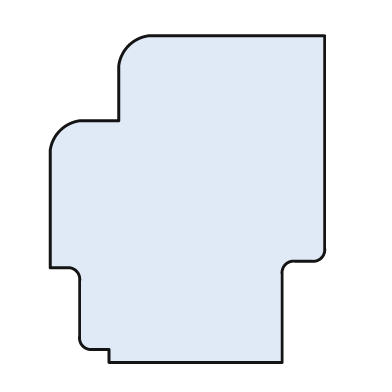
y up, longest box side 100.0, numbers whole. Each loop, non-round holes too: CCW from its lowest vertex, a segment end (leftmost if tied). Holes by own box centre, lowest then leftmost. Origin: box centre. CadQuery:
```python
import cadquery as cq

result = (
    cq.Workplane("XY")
    .moveTo(-24.0, -50.0)
    .lineTo(29.0, -50.0)
    .lineTo(29.0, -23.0)
    .threePointArc((30.0, -20.0), (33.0, -19.0))
    .lineTo(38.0, -19.0)
    .threePointArc((41.0, -18.0), (42.0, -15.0))
    .lineTo(42.0, 50.0)
    .lineTo(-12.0, 50.0)
    .threePointArc((-18.0, 47.0), (-21.0, 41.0))
    .lineTo(-21.0, 24.0)
    .lineTo(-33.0, 24.0)
    .threePointArc((-39.0, 21.0), (-42.0, 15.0))
    .lineTo(-42.0, -21.0)
    .lineTo(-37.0, -21.0)
    .threePointArc((-34.0, -22.0), (-33.0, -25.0))
    .lineTo(-33.0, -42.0)
    .threePointArc((-32.0, -45.0), (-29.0, -46.0))
    .lineTo(-24.0, -46.0)
    .close()
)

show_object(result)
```